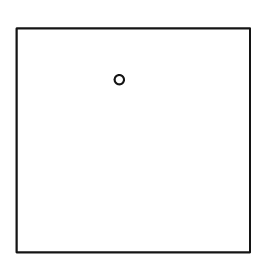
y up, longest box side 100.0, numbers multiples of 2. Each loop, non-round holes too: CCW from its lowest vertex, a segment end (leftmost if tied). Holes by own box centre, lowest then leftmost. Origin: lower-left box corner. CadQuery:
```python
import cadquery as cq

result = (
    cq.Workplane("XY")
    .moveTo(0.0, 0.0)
    .lineTo(100.0, 0.0)
    .lineTo(100.0, 96.0)
    .lineTo(0.0, 96.0)
    .close()
    .moveTo(44.0, 74.0)
    .circle(2.0)
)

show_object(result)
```